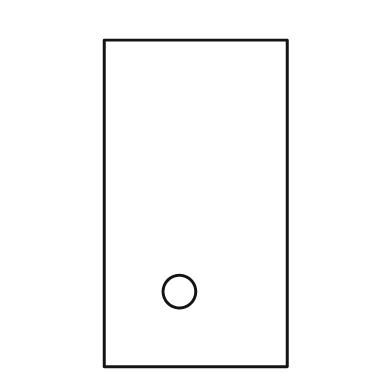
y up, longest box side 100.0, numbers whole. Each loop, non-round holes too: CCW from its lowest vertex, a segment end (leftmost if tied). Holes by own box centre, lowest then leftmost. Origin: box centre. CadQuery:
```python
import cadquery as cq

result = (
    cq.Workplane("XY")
    .moveTo(-28.0, -50.0)
    .lineTo(28.0, -50.0)
    .lineTo(28.0, 50.0)
    .lineTo(-28.0, 50.0)
    .close()
    .moveTo(-5.0, -27.0)
    .circle(5.0)
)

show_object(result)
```